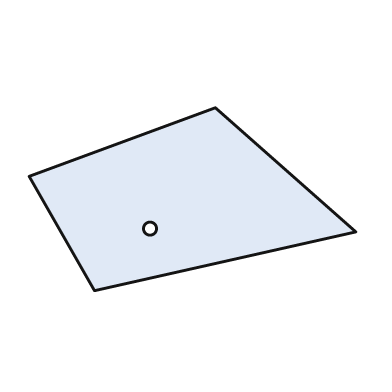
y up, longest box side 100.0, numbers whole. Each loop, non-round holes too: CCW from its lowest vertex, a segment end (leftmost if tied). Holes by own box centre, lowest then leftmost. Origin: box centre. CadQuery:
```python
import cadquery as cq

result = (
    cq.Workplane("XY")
    .moveTo(-30.0, -28.0)
    .lineTo(50.0, -10.0)
    .lineTo(7.0, 28.0)
    .lineTo(-50.0, 7.0)
    .close()
    .moveTo(-13.0, -9.0)
    .circle(2.0)
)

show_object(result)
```